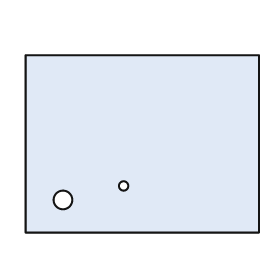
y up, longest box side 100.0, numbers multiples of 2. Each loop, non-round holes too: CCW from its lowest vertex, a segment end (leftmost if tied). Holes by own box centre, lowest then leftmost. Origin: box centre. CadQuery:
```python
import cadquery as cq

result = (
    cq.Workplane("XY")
    .moveTo(-50.0, -38.0)
    .lineTo(50.0, -38.0)
    .lineTo(50.0, 38.0)
    .lineTo(-50.0, 38.0)
    .close()
    .moveTo(-34.0, -24.0)
    .circle(4.0)
    .moveTo(-8.0, -18.0)
    .circle(2.0)
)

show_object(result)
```